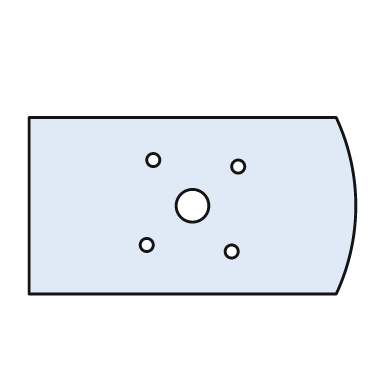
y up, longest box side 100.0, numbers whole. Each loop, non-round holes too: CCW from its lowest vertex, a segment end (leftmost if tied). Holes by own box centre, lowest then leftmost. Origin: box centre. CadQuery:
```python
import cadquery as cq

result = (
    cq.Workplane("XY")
    .moveTo(-50.0, -27.0)
    .lineTo(44.0, -27.0)
    .threePointArc((50.0, 0.0), (44.0, 27.0))
    .lineTo(-50.0, 27.0)
    .close()
    .moveTo(12.0, -14.0)
    .circle(2.0)
    .moveTo(-14.0, -12.0)
    .circle(2.0)
    .moveTo(0.0, 0.0)
    .circle(5.0)
    .moveTo(14.0, 12.0)
    .circle(2.0)
    .moveTo(-12.0, 14.0)
    .circle(2.0)
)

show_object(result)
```